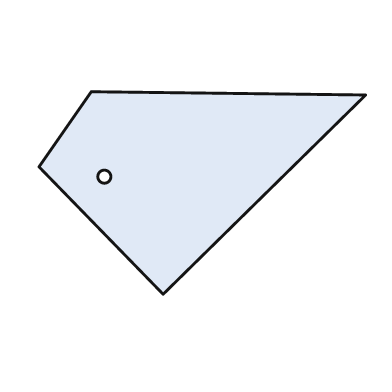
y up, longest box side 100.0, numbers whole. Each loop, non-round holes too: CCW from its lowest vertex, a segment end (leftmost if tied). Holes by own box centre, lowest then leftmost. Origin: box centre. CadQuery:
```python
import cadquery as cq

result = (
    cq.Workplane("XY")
    .moveTo(-12.0, -31.0)
    .lineTo(50.0, 30.0)
    .lineTo(-34.0, 31.0)
    .lineTo(-50.0, 8.0)
    .close()
    .moveTo(-30.0, 5.0)
    .circle(2.0)
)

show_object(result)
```